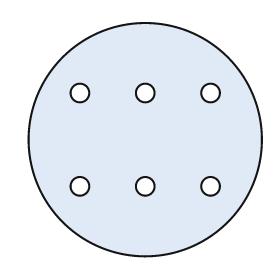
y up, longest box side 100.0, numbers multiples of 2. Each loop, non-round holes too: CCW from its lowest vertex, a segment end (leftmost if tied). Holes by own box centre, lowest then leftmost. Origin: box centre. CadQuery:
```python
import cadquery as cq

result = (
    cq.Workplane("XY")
    .moveTo(0.0, 0.0)
    .circle(50.0)
    .moveTo(-28.0, -20.0)
    .circle(4.0)
    .moveTo(0.0, -20.0)
    .circle(4.0)
    .moveTo(28.0, -20.0)
    .circle(4.0)
    .moveTo(-28.0, 20.0)
    .circle(4.0)
    .moveTo(0.0, 20.0)
    .circle(4.0)
    .moveTo(28.0, 20.0)
    .circle(4.0)
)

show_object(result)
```